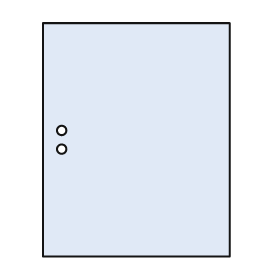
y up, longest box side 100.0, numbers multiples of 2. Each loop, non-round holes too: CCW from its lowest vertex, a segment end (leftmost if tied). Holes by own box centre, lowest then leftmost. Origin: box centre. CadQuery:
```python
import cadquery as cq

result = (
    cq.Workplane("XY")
    .moveTo(-40.0, -50.0)
    .lineTo(40.0, -50.0)
    .lineTo(40.0, 50.0)
    .lineTo(-40.0, 50.0)
    .close()
    .moveTo(-32.0, -4.0)
    .circle(2.0)
    .moveTo(-32.0, 4.0)
    .circle(2.0)
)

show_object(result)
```